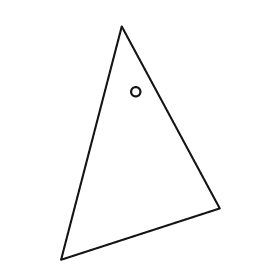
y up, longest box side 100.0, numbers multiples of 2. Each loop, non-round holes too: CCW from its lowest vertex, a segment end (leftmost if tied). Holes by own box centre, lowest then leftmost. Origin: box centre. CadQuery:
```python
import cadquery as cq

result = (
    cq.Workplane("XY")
    .moveTo(-34.0, -50.0)
    .lineTo(34.0, -28.0)
    .lineTo(-8.0, 50.0)
    .close()
    .moveTo(-2.0, 22.0)
    .circle(2.0)
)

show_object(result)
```